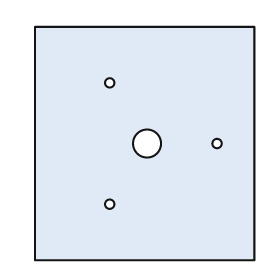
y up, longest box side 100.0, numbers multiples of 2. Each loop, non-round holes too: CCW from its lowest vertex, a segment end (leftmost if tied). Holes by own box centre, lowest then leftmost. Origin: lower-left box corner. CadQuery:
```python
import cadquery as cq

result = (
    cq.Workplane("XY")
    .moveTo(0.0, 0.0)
    .lineTo(94.0, 0.0)
    .lineTo(94.0, 100.0)
    .lineTo(0.0, 100.0)
    .close()
    .moveTo(32.0, 24.0)
    .circle(2.0)
    .moveTo(48.0, 50.0)
    .circle(6.0)
    .moveTo(78.0, 50.0)
    .circle(2.0)
    .moveTo(32.0, 76.0)
    .circle(2.0)
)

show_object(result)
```